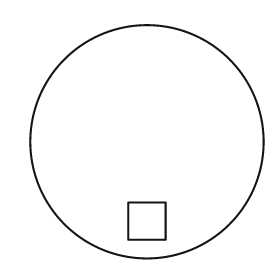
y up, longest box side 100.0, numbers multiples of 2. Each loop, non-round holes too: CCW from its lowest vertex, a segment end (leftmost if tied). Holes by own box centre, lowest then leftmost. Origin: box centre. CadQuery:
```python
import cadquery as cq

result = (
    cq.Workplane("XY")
    .moveTo(0.0, 0.0)
    .circle(50.0)
    .moveTo(-8.0, -42.0)
    .lineTo(8.0, -42.0)
    .lineTo(8.0, -26.0)
    .lineTo(-8.0, -26.0)
    .close()
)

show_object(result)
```